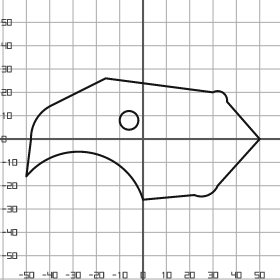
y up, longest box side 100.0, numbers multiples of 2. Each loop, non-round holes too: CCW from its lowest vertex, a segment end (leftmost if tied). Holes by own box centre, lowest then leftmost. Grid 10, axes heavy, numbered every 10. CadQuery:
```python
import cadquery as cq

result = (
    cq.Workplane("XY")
    .moveTo(0.0, -26.0)
    .lineTo(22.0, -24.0)
    .threePointArc((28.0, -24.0), (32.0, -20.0))
    .lineTo(50.0, 0.0)
    .lineTo(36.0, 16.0)
    .threePointArc((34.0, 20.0), (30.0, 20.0))
    .lineTo(-16.0, 26.0)
    .lineTo(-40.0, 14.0)
    .threePointArc((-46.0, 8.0), (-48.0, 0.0))
    .lineTo(-50.0, -16.0)
    .threePointArc((-22.0, -6.0), (0.0, -26.0))
    .close()
    .moveTo(-6.0, 8.0)
    .circle(4.0)
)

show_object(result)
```